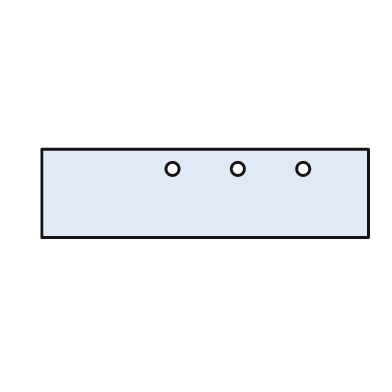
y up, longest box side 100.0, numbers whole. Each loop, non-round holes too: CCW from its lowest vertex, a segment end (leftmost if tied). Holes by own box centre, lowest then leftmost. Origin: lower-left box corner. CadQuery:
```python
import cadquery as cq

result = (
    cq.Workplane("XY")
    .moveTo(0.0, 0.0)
    .lineTo(100.0, 0.0)
    .lineTo(100.0, 27.0)
    .lineTo(0.0, 27.0)
    .close()
    .moveTo(40.0, 21.0)
    .circle(2.0)
    .moveTo(60.0, 21.0)
    .circle(2.0)
    .moveTo(80.0, 21.0)
    .circle(2.0)
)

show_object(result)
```